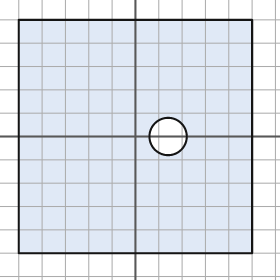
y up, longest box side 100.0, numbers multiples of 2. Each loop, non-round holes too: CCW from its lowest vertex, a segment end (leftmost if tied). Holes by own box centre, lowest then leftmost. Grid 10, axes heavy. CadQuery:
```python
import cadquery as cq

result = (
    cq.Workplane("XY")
    .moveTo(-50.0, -50.0)
    .lineTo(50.0, -50.0)
    .lineTo(50.0, 50.0)
    .lineTo(-50.0, 50.0)
    .close()
    .moveTo(14.0, 0.0)
    .circle(8.0)
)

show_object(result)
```